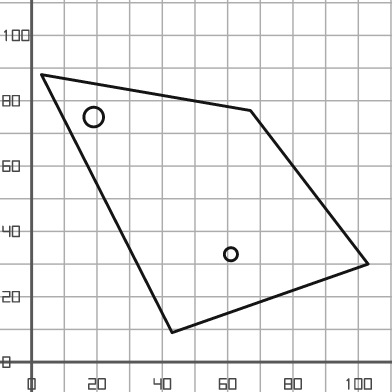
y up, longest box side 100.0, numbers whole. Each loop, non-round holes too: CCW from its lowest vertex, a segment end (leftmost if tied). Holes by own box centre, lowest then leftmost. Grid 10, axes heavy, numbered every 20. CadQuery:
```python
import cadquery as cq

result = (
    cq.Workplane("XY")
    .moveTo(43.0, 9.0)
    .lineTo(103.0, 30.0)
    .lineTo(67.0, 77.0)
    .lineTo(3.0, 88.0)
    .close()
    .moveTo(61.0, 33.0)
    .circle(2.0)
    .moveTo(19.0, 75.0)
    .circle(3.0)
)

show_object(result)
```